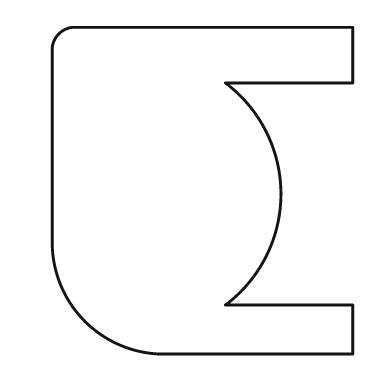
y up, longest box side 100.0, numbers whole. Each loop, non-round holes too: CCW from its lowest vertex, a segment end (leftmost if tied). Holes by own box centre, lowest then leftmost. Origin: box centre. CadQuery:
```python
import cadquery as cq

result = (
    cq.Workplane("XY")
    .moveTo(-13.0, -50.0)
    .lineTo(46.0, -50.0)
    .lineTo(46.0, -35.0)
    .lineTo(7.0, -35.0)
    .threePointArc((24.0, -1.0), (7.0, 33.0))
    .lineTo(46.0, 33.0)
    .lineTo(46.0, 50.0)
    .lineTo(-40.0, 50.0)
    .threePointArc((-44.0, 48.0), (-46.0, 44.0))
    .lineTo(-46.0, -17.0)
    .threePointArc((-36.0, -40.0), (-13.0, -50.0))
    .close()
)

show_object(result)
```